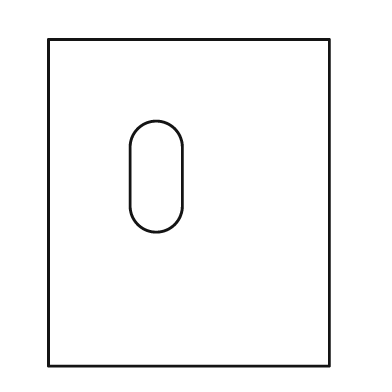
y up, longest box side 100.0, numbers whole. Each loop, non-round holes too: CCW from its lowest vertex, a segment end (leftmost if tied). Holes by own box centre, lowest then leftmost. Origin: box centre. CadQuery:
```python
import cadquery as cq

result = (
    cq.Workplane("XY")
    .moveTo(-43.0, -50.0)
    .lineTo(43.0, -50.0)
    .lineTo(43.0, 50.0)
    .lineTo(-43.0, 50.0)
    .close()
    .moveTo(-18.0, -1.0)
    .threePointArc((-10.0, -9.0), (-2.0, -1.0))
    .lineTo(-2.0, 17.0)
    .threePointArc((-10.0, 25.0), (-18.0, 17.0))
    .close()
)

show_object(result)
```